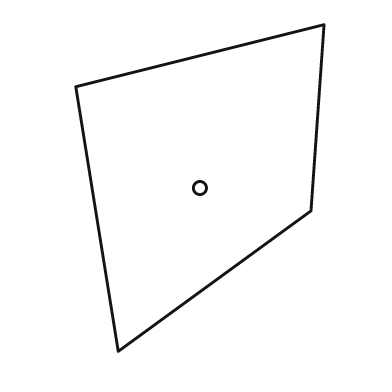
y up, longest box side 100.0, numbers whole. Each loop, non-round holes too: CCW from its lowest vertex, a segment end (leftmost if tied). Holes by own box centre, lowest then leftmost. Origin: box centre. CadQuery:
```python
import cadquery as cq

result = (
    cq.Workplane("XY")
    .moveTo(-25.0, -50.0)
    .lineTo(34.0, -7.0)
    .lineTo(38.0, 50.0)
    .lineTo(-38.0, 31.0)
    .close()
    .moveTo(0.0, 0.0)
    .circle(2.0)
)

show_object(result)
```